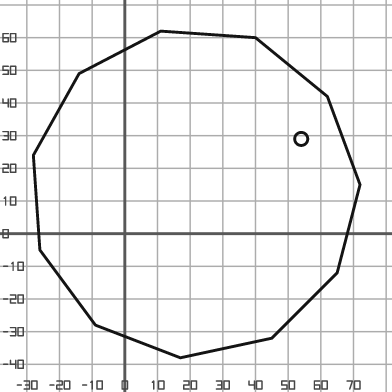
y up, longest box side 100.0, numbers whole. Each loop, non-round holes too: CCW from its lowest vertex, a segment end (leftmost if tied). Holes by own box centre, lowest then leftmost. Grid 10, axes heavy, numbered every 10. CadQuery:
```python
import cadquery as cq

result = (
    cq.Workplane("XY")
    .moveTo(17.0, -38.0)
    .lineTo(45.0, -32.0)
    .lineTo(65.0, -12.0)
    .lineTo(72.0, 15.0)
    .lineTo(62.0, 42.0)
    .lineTo(40.0, 60.0)
    .lineTo(11.0, 62.0)
    .lineTo(-14.0, 49.0)
    .lineTo(-28.0, 24.0)
    .lineTo(-26.0, -5.0)
    .lineTo(-9.0, -28.0)
    .close()
    .moveTo(54.0, 29.0)
    .circle(2.0)
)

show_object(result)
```